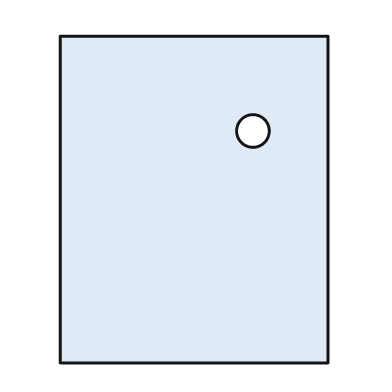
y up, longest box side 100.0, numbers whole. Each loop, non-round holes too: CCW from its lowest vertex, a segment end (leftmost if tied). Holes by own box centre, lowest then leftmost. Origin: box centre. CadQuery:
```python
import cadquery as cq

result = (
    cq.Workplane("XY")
    .moveTo(-41.0, -50.0)
    .lineTo(41.0, -50.0)
    .lineTo(41.0, 50.0)
    .lineTo(-41.0, 50.0)
    .close()
    .moveTo(18.0, 21.0)
    .circle(5.0)
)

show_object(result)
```